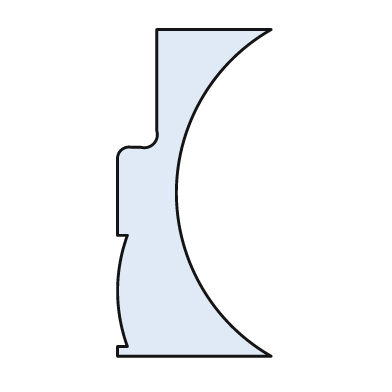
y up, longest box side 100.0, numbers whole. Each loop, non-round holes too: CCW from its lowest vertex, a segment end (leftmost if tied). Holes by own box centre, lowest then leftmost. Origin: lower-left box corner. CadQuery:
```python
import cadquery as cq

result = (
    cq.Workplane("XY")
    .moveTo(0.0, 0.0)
    .lineTo(47.0, 0.0)
    .threePointArc((18.0, 50.0), (47.0, 100.0))
    .lineTo(12.0, 100.0)
    .lineTo(12.0, 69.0)
    .threePointArc((11.0, 65.0), (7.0, 64.0))
    .lineTo(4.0, 64.0)
    .threePointArc((1.0, 63.0), (0.0, 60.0))
    .lineTo(0.0, 37.0)
    .lineTo(3.0, 37.0)
    .threePointArc((0.0, 20.0), (3.0, 3.0))
    .lineTo(0.0, 3.0)
    .close()
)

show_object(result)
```